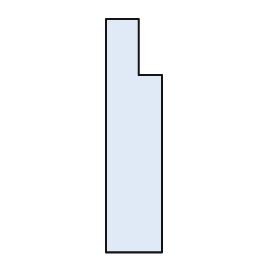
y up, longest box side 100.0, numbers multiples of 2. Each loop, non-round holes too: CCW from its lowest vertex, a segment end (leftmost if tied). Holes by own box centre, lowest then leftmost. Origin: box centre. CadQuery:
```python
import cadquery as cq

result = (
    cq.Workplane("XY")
    .moveTo(-12.0, -50.0)
    .lineTo(12.0, -50.0)
    .lineTo(12.0, 26.0)
    .lineTo(2.0, 26.0)
    .lineTo(2.0, 50.0)
    .lineTo(-12.0, 50.0)
    .close()
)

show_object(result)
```